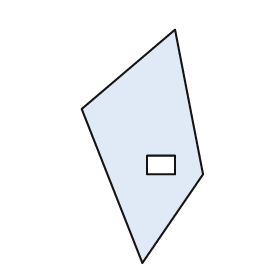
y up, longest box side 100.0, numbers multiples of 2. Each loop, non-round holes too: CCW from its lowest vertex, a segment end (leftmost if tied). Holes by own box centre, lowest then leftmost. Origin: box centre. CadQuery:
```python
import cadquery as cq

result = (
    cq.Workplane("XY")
    .moveTo(0.0, -50.0)
    .lineTo(26.0, -12.0)
    .lineTo(14.0, 50.0)
    .lineTo(-26.0, 16.0)
    .close()
    .moveTo(2.0, -12.0)
    .lineTo(14.0, -12.0)
    .lineTo(14.0, -4.0)
    .lineTo(2.0, -4.0)
    .close()
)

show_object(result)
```